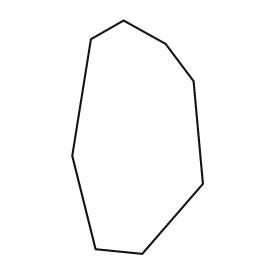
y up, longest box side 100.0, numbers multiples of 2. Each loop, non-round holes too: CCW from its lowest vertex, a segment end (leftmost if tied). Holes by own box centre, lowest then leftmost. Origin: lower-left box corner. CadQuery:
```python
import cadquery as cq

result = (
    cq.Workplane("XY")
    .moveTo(30.0, 0.0)
    .lineTo(56.0, 30.0)
    .lineTo(52.0, 74.0)
    .lineTo(40.0, 90.0)
    .lineTo(22.0, 100.0)
    .lineTo(8.0, 92.0)
    .lineTo(0.0, 42.0)
    .lineTo(10.0, 2.0)
    .close()
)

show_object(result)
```